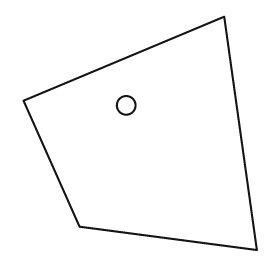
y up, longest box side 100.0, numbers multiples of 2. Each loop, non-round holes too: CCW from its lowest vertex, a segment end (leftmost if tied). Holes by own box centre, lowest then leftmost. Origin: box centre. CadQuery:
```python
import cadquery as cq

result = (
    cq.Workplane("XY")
    .moveTo(50.0, -50.0)
    .lineTo(36.0, 50.0)
    .lineTo(-50.0, 14.0)
    .lineTo(-26.0, -40.0)
    .close()
    .moveTo(-6.0, 12.0)
    .circle(4.0)
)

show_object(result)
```